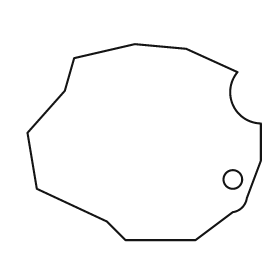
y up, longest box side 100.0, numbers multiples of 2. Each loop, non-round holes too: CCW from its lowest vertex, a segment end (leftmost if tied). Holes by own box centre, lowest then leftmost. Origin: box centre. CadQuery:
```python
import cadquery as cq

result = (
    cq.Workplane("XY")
    .moveTo(-8.0, -42.0)
    .lineTo(22.0, -42.0)
    .lineTo(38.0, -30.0)
    .threePointArc((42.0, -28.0), (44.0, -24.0))
    .lineTo(50.0, -8.0)
    .lineTo(50.0, 8.0)
    .threePointArc((38.0, 16.0), (40.0, 30.0))
    .lineTo(18.0, 40.0)
    .lineTo(-4.0, 42.0)
    .lineTo(-30.0, 36.0)
    .lineTo(-34.0, 22.0)
    .lineTo(-50.0, 4.0)
    .lineTo(-46.0, -20.0)
    .lineTo(-16.0, -34.0)
    .close()
    .moveTo(38.0, -16.0)
    .circle(4.0)
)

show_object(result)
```